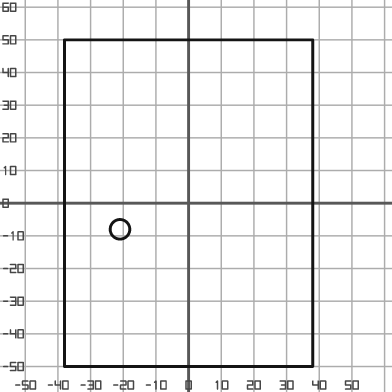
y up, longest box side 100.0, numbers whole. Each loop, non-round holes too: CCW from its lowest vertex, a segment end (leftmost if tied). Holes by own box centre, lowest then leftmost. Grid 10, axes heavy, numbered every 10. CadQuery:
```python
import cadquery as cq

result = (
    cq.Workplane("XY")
    .moveTo(-38.0, -50.0)
    .lineTo(38.0, -50.0)
    .lineTo(38.0, 50.0)
    .lineTo(-38.0, 50.0)
    .close()
    .moveTo(-21.0, -8.0)
    .circle(3.0)
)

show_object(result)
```